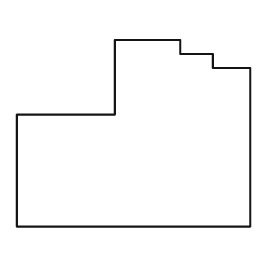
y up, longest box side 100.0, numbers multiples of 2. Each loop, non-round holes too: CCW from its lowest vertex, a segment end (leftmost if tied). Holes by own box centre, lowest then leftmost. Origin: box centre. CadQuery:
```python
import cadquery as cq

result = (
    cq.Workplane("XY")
    .moveTo(-50.0, -40.0)
    .lineTo(50.0, -40.0)
    .lineTo(50.0, 28.0)
    .lineTo(34.0, 28.0)
    .lineTo(34.0, 34.0)
    .lineTo(20.0, 34.0)
    .lineTo(20.0, 40.0)
    .lineTo(-8.0, 40.0)
    .lineTo(-8.0, 8.0)
    .lineTo(-50.0, 8.0)
    .close()
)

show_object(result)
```